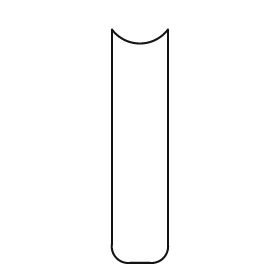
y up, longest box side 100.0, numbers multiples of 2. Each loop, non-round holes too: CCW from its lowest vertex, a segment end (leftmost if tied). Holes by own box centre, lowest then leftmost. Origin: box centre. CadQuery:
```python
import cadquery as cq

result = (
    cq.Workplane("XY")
    .moveTo(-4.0, -50.0)
    .lineTo(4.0, -50.0)
    .threePointArc((10.0, -48.0), (12.0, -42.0))
    .lineTo(12.0, 50.0)
    .threePointArc((0.0, 44.0), (-12.0, 50.0))
    .lineTo(-12.0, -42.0)
    .threePointArc((-10.0, -48.0), (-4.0, -50.0))
    .close()
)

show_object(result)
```